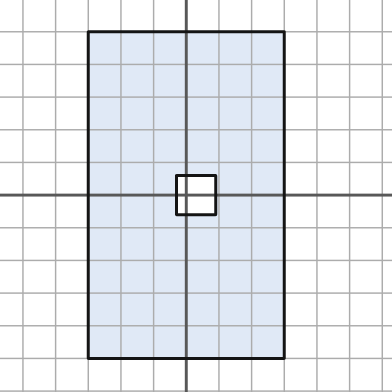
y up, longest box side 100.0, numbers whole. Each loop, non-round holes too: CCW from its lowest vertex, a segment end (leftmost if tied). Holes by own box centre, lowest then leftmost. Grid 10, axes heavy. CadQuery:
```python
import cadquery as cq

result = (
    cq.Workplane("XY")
    .moveTo(-30.0, -50.0)
    .lineTo(30.0, -50.0)
    .lineTo(30.0, 50.0)
    .lineTo(-30.0, 50.0)
    .close()
    .moveTo(-3.0, -6.0)
    .lineTo(9.0, -6.0)
    .lineTo(9.0, 6.0)
    .lineTo(-3.0, 6.0)
    .close()
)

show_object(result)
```